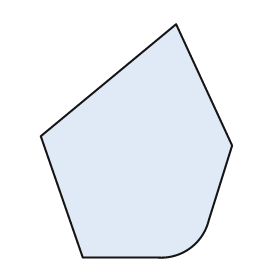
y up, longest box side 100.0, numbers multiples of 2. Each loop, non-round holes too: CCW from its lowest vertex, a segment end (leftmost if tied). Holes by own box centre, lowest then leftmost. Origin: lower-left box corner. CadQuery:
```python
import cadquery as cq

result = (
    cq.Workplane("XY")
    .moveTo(18.0, 0.0)
    .lineTo(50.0, 0.0)
    .threePointArc((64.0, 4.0), (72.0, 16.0))
    .lineTo(82.0, 48.0)
    .lineTo(58.0, 100.0)
    .lineTo(0.0, 52.0)
    .close()
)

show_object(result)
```